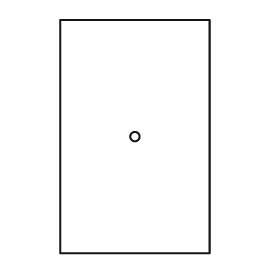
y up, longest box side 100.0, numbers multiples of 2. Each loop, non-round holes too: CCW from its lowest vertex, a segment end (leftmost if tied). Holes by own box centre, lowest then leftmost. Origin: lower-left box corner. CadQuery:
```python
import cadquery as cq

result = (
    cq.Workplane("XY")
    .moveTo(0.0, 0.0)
    .lineTo(64.0, 0.0)
    .lineTo(64.0, 100.0)
    .lineTo(0.0, 100.0)
    .close()
    .moveTo(32.0, 50.0)
    .circle(2.0)
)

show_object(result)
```